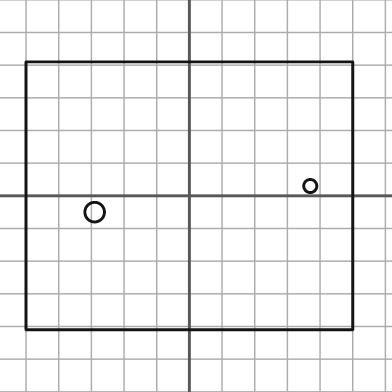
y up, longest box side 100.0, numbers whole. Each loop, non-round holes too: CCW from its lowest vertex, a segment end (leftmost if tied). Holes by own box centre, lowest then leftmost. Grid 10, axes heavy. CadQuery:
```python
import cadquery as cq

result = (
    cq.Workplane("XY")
    .moveTo(-50.0, -41.0)
    .lineTo(50.0, -41.0)
    .lineTo(50.0, 41.0)
    .lineTo(-50.0, 41.0)
    .close()
    .moveTo(-29.0, -5.0)
    .circle(3.0)
    .moveTo(37.0, 3.0)
    .circle(2.0)
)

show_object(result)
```